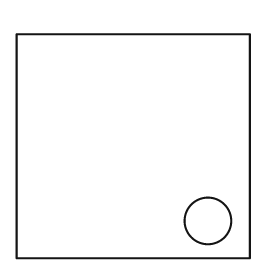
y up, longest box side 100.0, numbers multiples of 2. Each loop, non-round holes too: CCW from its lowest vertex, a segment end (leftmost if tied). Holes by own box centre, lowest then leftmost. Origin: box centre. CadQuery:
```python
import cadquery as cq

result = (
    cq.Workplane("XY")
    .moveTo(-50.0, -48.0)
    .lineTo(50.0, -48.0)
    .lineTo(50.0, 48.0)
    .lineTo(-50.0, 48.0)
    .close()
    .moveTo(32.0, -32.0)
    .circle(10.0)
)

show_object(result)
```